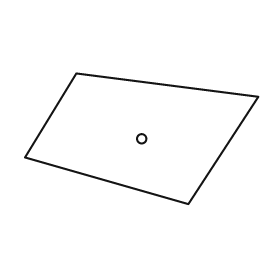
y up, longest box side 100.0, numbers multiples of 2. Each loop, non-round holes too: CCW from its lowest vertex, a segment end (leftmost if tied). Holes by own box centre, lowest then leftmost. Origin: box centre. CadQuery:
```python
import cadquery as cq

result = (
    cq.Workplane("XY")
    .moveTo(20.0, -28.0)
    .lineTo(50.0, 18.0)
    .lineTo(-28.0, 28.0)
    .lineTo(-50.0, -8.0)
    .close()
    .moveTo(0.0, 0.0)
    .circle(2.0)
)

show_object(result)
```